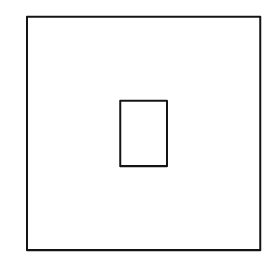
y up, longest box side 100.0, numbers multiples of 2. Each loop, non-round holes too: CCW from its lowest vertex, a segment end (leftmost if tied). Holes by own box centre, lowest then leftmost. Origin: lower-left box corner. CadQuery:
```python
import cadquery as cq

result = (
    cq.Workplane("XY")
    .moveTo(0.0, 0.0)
    .lineTo(100.0, 0.0)
    .lineTo(100.0, 100.0)
    .lineTo(0.0, 100.0)
    .close()
    .moveTo(40.0, 36.0)
    .lineTo(60.0, 36.0)
    .lineTo(60.0, 64.0)
    .lineTo(40.0, 64.0)
    .close()
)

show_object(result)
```